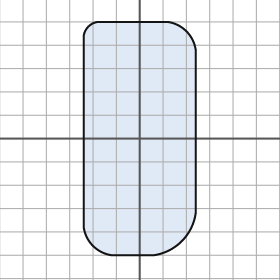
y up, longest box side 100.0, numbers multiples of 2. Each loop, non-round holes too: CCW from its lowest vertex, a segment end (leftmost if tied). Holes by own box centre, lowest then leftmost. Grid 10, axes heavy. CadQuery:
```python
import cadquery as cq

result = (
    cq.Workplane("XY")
    .moveTo(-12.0, -50.0)
    .lineTo(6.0, -50.0)
    .threePointArc((18.0, -44.0), (24.0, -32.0))
    .lineTo(24.0, 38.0)
    .threePointArc((20.0, 46.0), (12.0, 50.0))
    .lineTo(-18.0, 50.0)
    .threePointArc((-22.0, 48.0), (-24.0, 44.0))
    .lineTo(-24.0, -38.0)
    .threePointArc((-20.0, -46.0), (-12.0, -50.0))
    .close()
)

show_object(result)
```